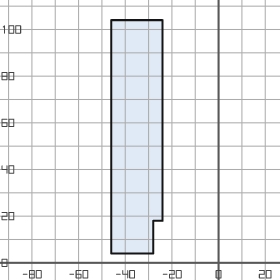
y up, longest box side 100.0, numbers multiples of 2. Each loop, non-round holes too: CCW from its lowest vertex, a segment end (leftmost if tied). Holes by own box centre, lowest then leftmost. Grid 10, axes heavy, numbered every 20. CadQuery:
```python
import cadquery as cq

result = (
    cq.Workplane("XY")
    .moveTo(-46.0, 4.0)
    .lineTo(-28.0, 4.0)
    .lineTo(-28.0, 18.0)
    .lineTo(-24.0, 18.0)
    .lineTo(-24.0, 104.0)
    .lineTo(-46.0, 104.0)
    .close()
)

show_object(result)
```